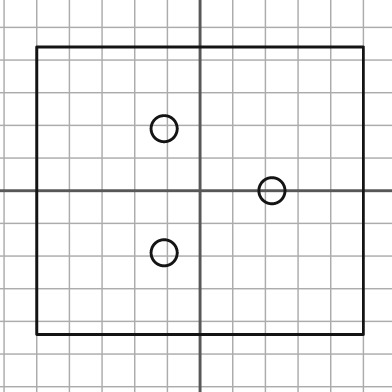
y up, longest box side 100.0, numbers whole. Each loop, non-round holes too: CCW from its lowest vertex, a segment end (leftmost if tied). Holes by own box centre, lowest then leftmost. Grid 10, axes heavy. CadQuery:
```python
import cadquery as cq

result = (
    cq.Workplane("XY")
    .moveTo(-50.0, -44.0)
    .lineTo(50.0, -44.0)
    .lineTo(50.0, 44.0)
    .lineTo(-50.0, 44.0)
    .close()
    .moveTo(-11.0, -19.0)
    .circle(4.0)
    .moveTo(22.0, 0.0)
    .circle(4.0)
    .moveTo(-11.0, 19.0)
    .circle(4.0)
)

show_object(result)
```